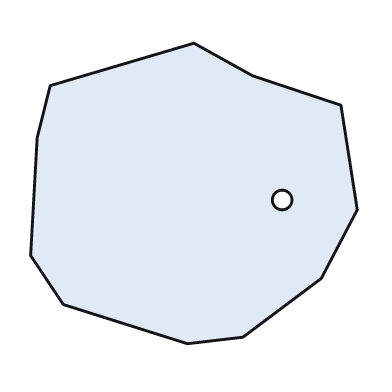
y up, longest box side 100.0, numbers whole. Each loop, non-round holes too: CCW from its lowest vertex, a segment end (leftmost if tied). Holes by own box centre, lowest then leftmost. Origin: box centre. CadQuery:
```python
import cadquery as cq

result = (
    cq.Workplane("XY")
    .moveTo(-2.0, -46.0)
    .lineTo(15.0, -44.0)
    .lineTo(39.0, -26.0)
    .lineTo(50.0, -5.0)
    .lineTo(45.0, 27.0)
    .lineTo(18.0, 36.0)
    .lineTo(0.0, 46.0)
    .lineTo(-44.0, 33.0)
    .lineTo(-48.0, 17.0)
    .lineTo(-50.0, -19.0)
    .lineTo(-40.0, -34.0)
    .close()
    .moveTo(27.0, -2.0)
    .circle(3.0)
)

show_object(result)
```